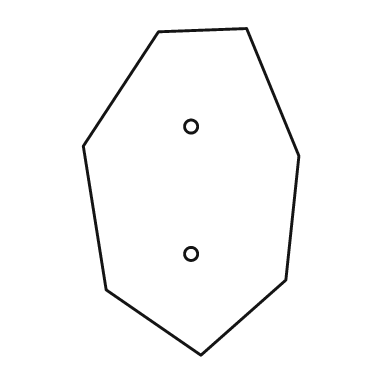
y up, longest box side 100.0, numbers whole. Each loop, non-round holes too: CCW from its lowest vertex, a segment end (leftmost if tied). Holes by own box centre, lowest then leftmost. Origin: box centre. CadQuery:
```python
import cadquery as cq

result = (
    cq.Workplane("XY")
    .moveTo(3.0, -50.0)
    .lineTo(29.0, -27.0)
    .lineTo(33.0, 11.0)
    .lineTo(17.0, 50.0)
    .lineTo(-10.0, 49.0)
    .lineTo(-33.0, 14.0)
    .lineTo(-26.0, -30.0)
    .close()
    .moveTo(0.0, -19.0)
    .circle(2.0)
    .moveTo(0.0, 20.0)
    .circle(2.0)
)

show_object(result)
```